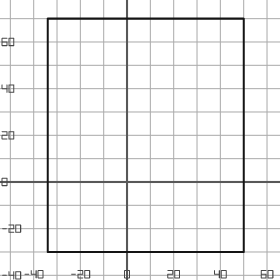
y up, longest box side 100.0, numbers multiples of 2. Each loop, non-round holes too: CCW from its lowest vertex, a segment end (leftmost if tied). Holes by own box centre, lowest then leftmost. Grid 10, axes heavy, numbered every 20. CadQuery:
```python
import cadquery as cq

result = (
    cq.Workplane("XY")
    .moveTo(-34.0, -30.0)
    .lineTo(50.0, -30.0)
    .lineTo(50.0, 70.0)
    .lineTo(-34.0, 70.0)
    .close()
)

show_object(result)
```